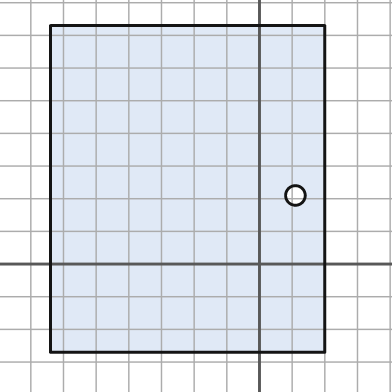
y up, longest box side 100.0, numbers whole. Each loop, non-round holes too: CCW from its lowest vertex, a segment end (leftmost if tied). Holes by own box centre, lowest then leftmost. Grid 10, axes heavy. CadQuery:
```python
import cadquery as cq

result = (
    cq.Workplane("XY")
    .moveTo(-64.0, -27.0)
    .lineTo(20.0, -27.0)
    .lineTo(20.0, 73.0)
    .lineTo(-64.0, 73.0)
    .close()
    .moveTo(11.0, 21.0)
    .circle(3.0)
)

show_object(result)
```